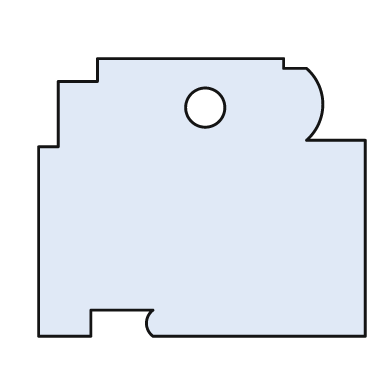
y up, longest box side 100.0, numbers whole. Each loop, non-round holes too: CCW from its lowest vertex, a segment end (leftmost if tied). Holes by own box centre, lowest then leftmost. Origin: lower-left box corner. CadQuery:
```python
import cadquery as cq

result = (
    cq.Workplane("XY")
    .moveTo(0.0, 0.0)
    .lineTo(16.0, 0.0)
    .lineTo(16.0, 8.0)
    .lineTo(35.0, 8.0)
    .threePointArc((33.0, 4.0), (35.0, 0.0))
    .lineTo(100.0, 0.0)
    .lineTo(100.0, 60.0)
    .lineTo(82.0, 60.0)
    .threePointArc((87.0, 71.0), (82.0, 82.0))
    .lineTo(75.0, 82.0)
    .lineTo(75.0, 85.0)
    .lineTo(18.0, 85.0)
    .lineTo(18.0, 78.0)
    .lineTo(6.0, 78.0)
    .lineTo(6.0, 58.0)
    .lineTo(0.0, 58.0)
    .close()
    .moveTo(51.0, 70.0)
    .circle(6.0)
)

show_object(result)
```